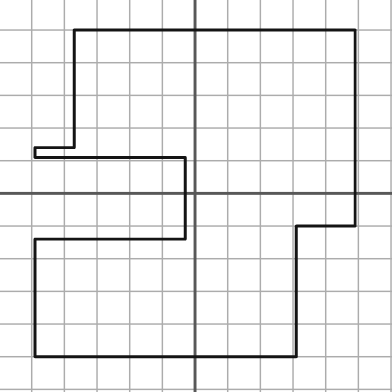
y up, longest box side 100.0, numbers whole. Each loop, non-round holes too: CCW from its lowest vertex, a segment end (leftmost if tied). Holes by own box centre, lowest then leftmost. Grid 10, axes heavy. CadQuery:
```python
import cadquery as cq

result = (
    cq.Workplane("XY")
    .moveTo(-49.0, -50.0)
    .lineTo(31.0, -50.0)
    .lineTo(31.0, -10.0)
    .lineTo(49.0, -10.0)
    .lineTo(49.0, 50.0)
    .lineTo(-37.0, 50.0)
    .lineTo(-37.0, 14.0)
    .lineTo(-49.0, 14.0)
    .lineTo(-49.0, 11.0)
    .lineTo(-3.0, 11.0)
    .lineTo(-3.0, -14.0)
    .lineTo(-49.0, -14.0)
    .close()
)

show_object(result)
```